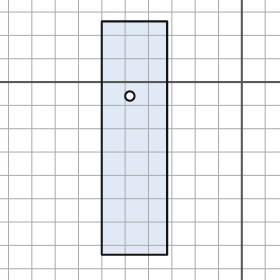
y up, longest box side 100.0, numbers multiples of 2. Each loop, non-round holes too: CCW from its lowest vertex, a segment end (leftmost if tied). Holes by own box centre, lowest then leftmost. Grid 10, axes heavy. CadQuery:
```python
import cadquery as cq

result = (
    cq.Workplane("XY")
    .moveTo(-60.0, -74.0)
    .lineTo(-32.0, -74.0)
    .lineTo(-32.0, 26.0)
    .lineTo(-60.0, 26.0)
    .close()
    .moveTo(-48.0, -6.0)
    .circle(2.0)
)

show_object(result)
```